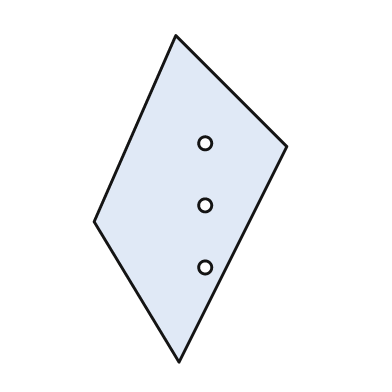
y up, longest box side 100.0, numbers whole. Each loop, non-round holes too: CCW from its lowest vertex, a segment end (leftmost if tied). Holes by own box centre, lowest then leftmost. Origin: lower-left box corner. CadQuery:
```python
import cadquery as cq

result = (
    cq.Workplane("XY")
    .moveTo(26.0, 0.0)
    .lineTo(59.0, 66.0)
    .lineTo(25.0, 100.0)
    .lineTo(0.0, 43.0)
    .close()
    .moveTo(34.0, 29.0)
    .circle(2.0)
    .moveTo(34.0, 48.0)
    .circle(2.0)
    .moveTo(34.0, 67.0)
    .circle(2.0)
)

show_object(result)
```